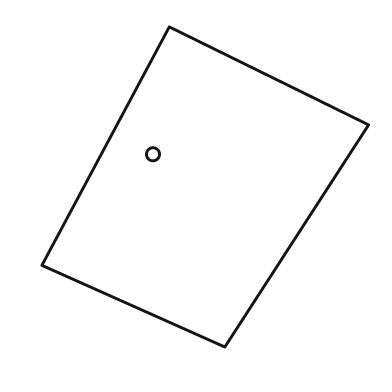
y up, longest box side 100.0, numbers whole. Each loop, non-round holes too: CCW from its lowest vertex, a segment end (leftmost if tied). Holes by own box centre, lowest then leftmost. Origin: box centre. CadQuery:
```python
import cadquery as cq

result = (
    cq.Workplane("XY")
    .moveTo(6.0, -49.0)
    .lineTo(50.0, 19.0)
    .lineTo(-11.0, 49.0)
    .lineTo(-50.0, -24.0)
    .close()
    .moveTo(-16.0, 10.0)
    .circle(2.0)
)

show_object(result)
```